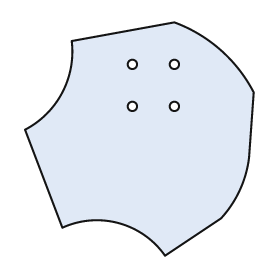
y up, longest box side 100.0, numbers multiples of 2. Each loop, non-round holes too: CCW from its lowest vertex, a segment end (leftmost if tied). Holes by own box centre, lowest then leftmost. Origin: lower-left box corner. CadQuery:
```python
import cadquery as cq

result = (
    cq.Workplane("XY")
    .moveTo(60.0, 0.0)
    .lineTo(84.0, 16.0)
    .threePointArc((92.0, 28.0), (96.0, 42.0))
    .lineTo(98.0, 70.0)
    .threePointArc((84.0, 88.0), (64.0, 100.0))
    .lineTo(20.0, 92.0)
    .threePointArc((16.0, 70.0), (0.0, 54.0))
    .lineTo(16.0, 12.0)
    .threePointArc((40.0, 14.0), (60.0, 0.0))
    .close()
    .moveTo(46.0, 64.0)
    .circle(2.0)
    .moveTo(64.0, 64.0)
    .circle(2.0)
    .moveTo(46.0, 82.0)
    .circle(2.0)
    .moveTo(64.0, 82.0)
    .circle(2.0)
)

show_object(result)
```